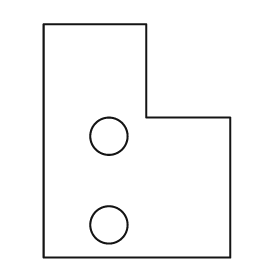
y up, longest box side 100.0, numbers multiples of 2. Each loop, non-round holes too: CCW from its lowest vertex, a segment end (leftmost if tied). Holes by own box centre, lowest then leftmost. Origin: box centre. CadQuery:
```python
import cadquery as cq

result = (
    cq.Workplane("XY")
    .moveTo(-40.0, -50.0)
    .lineTo(40.0, -50.0)
    .lineTo(40.0, 10.0)
    .lineTo(4.0, 10.0)
    .lineTo(4.0, 50.0)
    .lineTo(-40.0, 50.0)
    .close()
    .moveTo(-12.0, -36.0)
    .circle(8.0)
    .moveTo(-12.0, 2.0)
    .circle(8.0)
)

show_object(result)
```